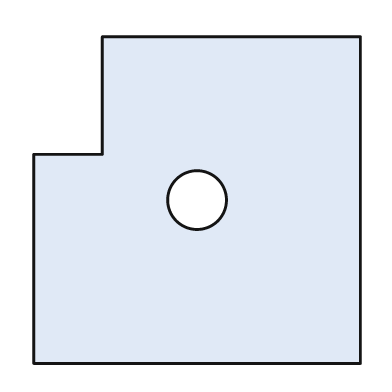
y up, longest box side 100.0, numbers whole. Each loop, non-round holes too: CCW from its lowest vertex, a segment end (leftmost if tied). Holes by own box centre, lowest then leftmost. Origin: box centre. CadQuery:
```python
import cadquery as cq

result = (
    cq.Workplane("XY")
    .moveTo(-50.0, -50.0)
    .lineTo(50.0, -50.0)
    .lineTo(50.0, 50.0)
    .lineTo(-29.0, 50.0)
    .lineTo(-29.0, 14.0)
    .lineTo(-50.0, 14.0)
    .close()
    .moveTo(0.0, 0.0)
    .circle(9.0)
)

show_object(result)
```